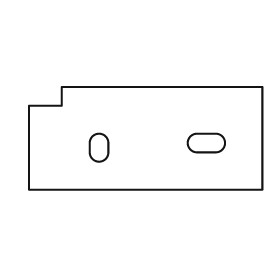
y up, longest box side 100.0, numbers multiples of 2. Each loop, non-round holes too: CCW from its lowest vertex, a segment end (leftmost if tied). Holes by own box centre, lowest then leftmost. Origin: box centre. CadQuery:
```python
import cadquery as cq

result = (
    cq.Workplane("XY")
    .moveTo(-50.0, -22.0)
    .lineTo(50.0, -22.0)
    .lineTo(50.0, 22.0)
    .lineTo(-36.0, 22.0)
    .lineTo(-36.0, 14.0)
    .lineTo(-50.0, 14.0)
    .close()
    .moveTo(-24.0, -6.0)
    .threePointArc((-20.0, -10.0), (-16.0, -6.0))
    .lineTo(-16.0, -2.0)
    .threePointArc((-20.0, 2.0), (-24.0, -2.0))
    .close()
    .moveTo(22.0, -6.0)
    .lineTo(30.0, -6.0)
    .threePointArc((34.0, -2.0), (30.0, 2.0))
    .lineTo(22.0, 2.0)
    .threePointArc((18.0, -2.0), (22.0, -6.0))
    .close()
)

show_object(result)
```